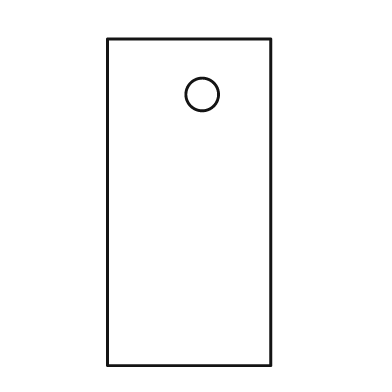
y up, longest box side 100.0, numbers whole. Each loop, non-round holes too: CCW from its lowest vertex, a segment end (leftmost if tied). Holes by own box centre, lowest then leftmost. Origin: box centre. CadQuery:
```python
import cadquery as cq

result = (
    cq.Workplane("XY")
    .moveTo(-25.0, -50.0)
    .lineTo(25.0, -50.0)
    .lineTo(25.0, 50.0)
    .lineTo(-25.0, 50.0)
    .close()
    .moveTo(4.0, 33.0)
    .circle(5.0)
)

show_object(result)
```